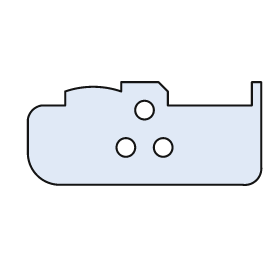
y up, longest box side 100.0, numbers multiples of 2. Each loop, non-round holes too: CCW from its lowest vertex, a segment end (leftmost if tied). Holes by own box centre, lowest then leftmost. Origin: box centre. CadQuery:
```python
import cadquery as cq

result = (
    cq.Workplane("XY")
    .moveTo(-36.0, -22.0)
    .lineTo(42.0, -22.0)
    .threePointArc((48.0, -20.0), (50.0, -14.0))
    .lineTo(50.0, 22.0)
    .lineTo(46.0, 22.0)
    .lineTo(46.0, 12.0)
    .lineTo(10.0, 12.0)
    .lineTo(10.0, 18.0)
    .lineTo(6.0, 22.0)
    .lineTo(-10.0, 22.0)
    .lineTo(-10.0, 18.0)
    .threePointArc((-22.0, 20.0), (-34.0, 18.0))
    .lineTo(-34.0, 12.0)
    .lineTo(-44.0, 12.0)
    .threePointArc((-48.0, 10.0), (-50.0, 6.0))
    .lineTo(-50.0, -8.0)
    .threePointArc((-46.0, -18.0), (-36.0, -22.0))
    .close()
    .moveTo(-8.0, -6.0)
    .circle(4.0)
    .moveTo(8.0, -6.0)
    .circle(4.0)
    .moveTo(0.0, 10.0)
    .circle(4.0)
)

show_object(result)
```